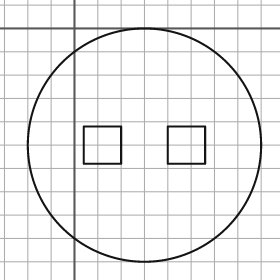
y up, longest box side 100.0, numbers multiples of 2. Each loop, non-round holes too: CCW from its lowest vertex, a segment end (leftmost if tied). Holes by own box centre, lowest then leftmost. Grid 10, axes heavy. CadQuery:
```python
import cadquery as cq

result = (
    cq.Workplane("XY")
    .moveTo(30.0, -50.0)
    .circle(50.0)
    .moveTo(4.0, -58.0)
    .lineTo(20.0, -58.0)
    .lineTo(20.0, -42.0)
    .lineTo(4.0, -42.0)
    .close()
    .moveTo(40.0, -58.0)
    .lineTo(56.0, -58.0)
    .lineTo(56.0, -42.0)
    .lineTo(40.0, -42.0)
    .close()
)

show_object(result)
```